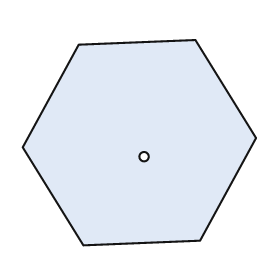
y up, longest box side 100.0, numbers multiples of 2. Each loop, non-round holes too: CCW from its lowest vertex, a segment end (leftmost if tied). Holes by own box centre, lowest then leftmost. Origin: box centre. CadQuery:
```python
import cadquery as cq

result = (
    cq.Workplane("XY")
    .moveTo(-24.0, -44.0)
    .lineTo(26.0, -42.0)
    .lineTo(50.0, 2.0)
    .lineTo(24.0, 44.0)
    .lineTo(-26.0, 42.0)
    .lineTo(-50.0, -2.0)
    .close()
    .moveTo(2.0, -6.0)
    .circle(2.0)
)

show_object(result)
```